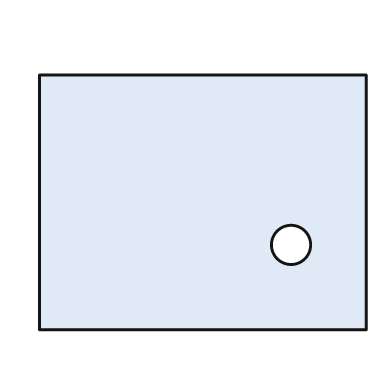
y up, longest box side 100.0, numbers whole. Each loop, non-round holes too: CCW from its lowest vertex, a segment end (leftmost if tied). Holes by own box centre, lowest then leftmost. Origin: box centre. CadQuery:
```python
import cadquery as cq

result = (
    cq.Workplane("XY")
    .moveTo(-50.0, -39.0)
    .lineTo(50.0, -39.0)
    .lineTo(50.0, 39.0)
    .lineTo(-50.0, 39.0)
    .close()
    .moveTo(27.0, -13.0)
    .circle(6.0)
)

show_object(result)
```